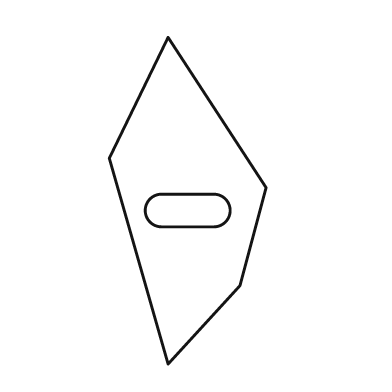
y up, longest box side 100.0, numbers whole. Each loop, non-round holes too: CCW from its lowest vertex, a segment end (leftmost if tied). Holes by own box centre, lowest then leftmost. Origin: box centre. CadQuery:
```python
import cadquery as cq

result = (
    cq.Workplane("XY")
    .moveTo(-6.0, -50.0)
    .lineTo(16.0, -26.0)
    .lineTo(24.0, 4.0)
    .lineTo(-6.0, 50.0)
    .lineTo(-24.0, 13.0)
    .close()
    .moveTo(-8.0, -8.0)
    .lineTo(8.0, -8.0)
    .threePointArc((13.0, -3.0), (8.0, 2.0))
    .lineTo(-8.0, 2.0)
    .threePointArc((-13.0, -3.0), (-8.0, -8.0))
    .close()
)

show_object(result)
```